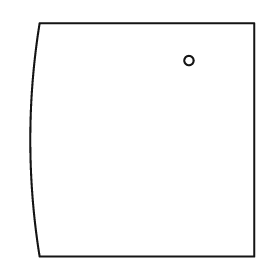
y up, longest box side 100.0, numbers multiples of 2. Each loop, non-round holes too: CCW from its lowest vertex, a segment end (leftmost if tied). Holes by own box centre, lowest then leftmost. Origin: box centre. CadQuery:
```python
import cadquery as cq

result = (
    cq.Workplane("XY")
    .moveTo(-44.0, -50.0)
    .lineTo(48.0, -50.0)
    .lineTo(48.0, 50.0)
    .lineTo(-44.0, 50.0)
    .threePointArc((-48.0, 0.0), (-44.0, -50.0))
    .close()
    .moveTo(20.0, 34.0)
    .circle(2.0)
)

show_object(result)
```